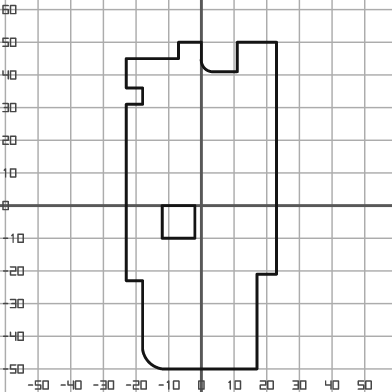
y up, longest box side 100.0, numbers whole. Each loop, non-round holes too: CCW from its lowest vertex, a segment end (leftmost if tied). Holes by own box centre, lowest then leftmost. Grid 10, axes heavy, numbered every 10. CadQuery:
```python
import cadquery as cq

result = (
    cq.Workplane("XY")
    .moveTo(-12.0, -50.0)
    .lineTo(17.0, -50.0)
    .lineTo(17.0, -21.0)
    .lineTo(23.0, -21.0)
    .lineTo(23.0, 50.0)
    .lineTo(11.0, 50.0)
    .lineTo(11.0, 41.0)
    .lineTo(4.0, 41.0)
    .threePointArc((1.0, 42.0), (0.0, 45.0))
    .lineTo(0.0, 50.0)
    .lineTo(-7.0, 50.0)
    .lineTo(-7.0, 45.0)
    .lineTo(-23.0, 45.0)
    .lineTo(-23.0, 36.0)
    .lineTo(-18.0, 36.0)
    .lineTo(-18.0, 31.0)
    .lineTo(-23.0, 31.0)
    .lineTo(-23.0, -23.0)
    .lineTo(-18.0, -23.0)
    .lineTo(-18.0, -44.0)
    .threePointArc((-16.0, -48.0), (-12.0, -50.0))
    .close()
    .moveTo(-12.0, -10.0)
    .lineTo(-2.0, -10.0)
    .lineTo(-2.0, 0.0)
    .lineTo(-12.0, 0.0)
    .close()
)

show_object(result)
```